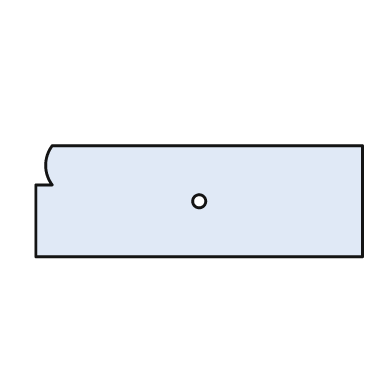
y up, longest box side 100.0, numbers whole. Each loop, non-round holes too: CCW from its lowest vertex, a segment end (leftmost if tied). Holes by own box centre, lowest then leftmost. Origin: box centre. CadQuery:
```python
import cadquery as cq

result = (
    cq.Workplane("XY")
    .moveTo(-50.0, -17.0)
    .lineTo(50.0, -17.0)
    .lineTo(50.0, 17.0)
    .lineTo(-45.0, 17.0)
    .threePointArc((-47.0, 11.0), (-45.0, 5.0))
    .lineTo(-50.0, 5.0)
    .close()
    .moveTo(0.0, 0.0)
    .circle(2.0)
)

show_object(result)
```